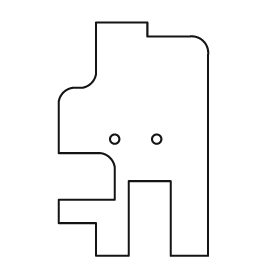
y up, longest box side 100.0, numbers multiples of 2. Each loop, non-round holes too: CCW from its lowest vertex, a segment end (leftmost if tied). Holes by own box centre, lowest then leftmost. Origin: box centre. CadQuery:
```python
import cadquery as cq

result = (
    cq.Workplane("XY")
    .moveTo(-16.0, -50.0)
    .lineTo(-2.0, -50.0)
    .lineTo(-2.0, -18.0)
    .lineTo(16.0, -18.0)
    .lineTo(16.0, -50.0)
    .lineTo(32.0, -50.0)
    .lineTo(32.0, 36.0)
    .threePointArc((30.0, 42.0), (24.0, 44.0))
    .lineTo(6.0, 44.0)
    .lineTo(6.0, 50.0)
    .lineTo(-16.0, 50.0)
    .lineTo(-16.0, 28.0)
    .threePointArc((-18.0, 24.0), (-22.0, 22.0))
    .lineTo(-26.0, 22.0)
    .threePointArc((-30.0, 20.0), (-32.0, 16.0))
    .lineTo(-32.0, -6.0)
    .lineTo(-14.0, -6.0)
    .threePointArc((-10.0, -8.0), (-8.0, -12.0))
    .lineTo(-8.0, -26.0)
    .lineTo(-32.0, -26.0)
    .lineTo(-32.0, -36.0)
    .lineTo(-16.0, -36.0)
    .close()
    .moveTo(-8.0, 0.0)
    .circle(2.0)
    .moveTo(10.0, 0.0)
    .circle(2.0)
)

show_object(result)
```